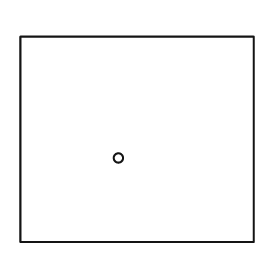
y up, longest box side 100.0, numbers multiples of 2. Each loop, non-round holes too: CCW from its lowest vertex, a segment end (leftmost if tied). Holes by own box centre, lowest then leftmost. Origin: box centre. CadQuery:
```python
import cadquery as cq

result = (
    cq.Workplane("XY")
    .moveTo(-50.0, -44.0)
    .lineTo(50.0, -44.0)
    .lineTo(50.0, 44.0)
    .lineTo(-50.0, 44.0)
    .close()
    .moveTo(-8.0, -8.0)
    .circle(2.0)
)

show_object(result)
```